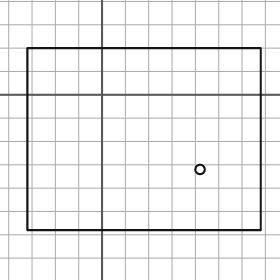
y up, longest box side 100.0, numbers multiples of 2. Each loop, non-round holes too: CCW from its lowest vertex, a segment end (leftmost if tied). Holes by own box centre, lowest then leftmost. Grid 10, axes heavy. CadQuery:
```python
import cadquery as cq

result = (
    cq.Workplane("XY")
    .moveTo(-32.0, -58.0)
    .lineTo(68.0, -58.0)
    .lineTo(68.0, 20.0)
    .lineTo(-32.0, 20.0)
    .close()
    .moveTo(42.0, -32.0)
    .circle(2.0)
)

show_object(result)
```